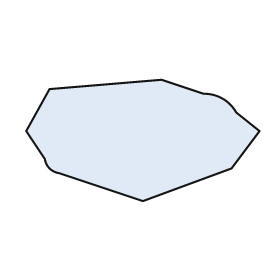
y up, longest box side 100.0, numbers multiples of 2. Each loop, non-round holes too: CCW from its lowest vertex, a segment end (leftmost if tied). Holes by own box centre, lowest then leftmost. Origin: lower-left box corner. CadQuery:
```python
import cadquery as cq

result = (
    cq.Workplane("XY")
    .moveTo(50.0, 0.0)
    .lineTo(88.0, 14.0)
    .lineTo(100.0, 30.0)
    .lineTo(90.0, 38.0)
    .threePointArc((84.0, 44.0), (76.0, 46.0))
    .lineTo(58.0, 52.0)
    .lineTo(10.0, 48.0)
    .lineTo(0.0, 30.0)
    .lineTo(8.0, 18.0)
    .threePointArc((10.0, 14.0), (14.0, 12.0))
    .close()
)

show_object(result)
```